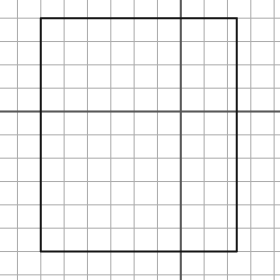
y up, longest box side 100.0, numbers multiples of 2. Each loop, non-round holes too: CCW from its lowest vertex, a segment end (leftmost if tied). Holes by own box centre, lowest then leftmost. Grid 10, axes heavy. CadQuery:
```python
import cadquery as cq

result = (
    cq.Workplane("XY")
    .moveTo(-60.0, -60.0)
    .lineTo(24.0, -60.0)
    .lineTo(24.0, 40.0)
    .lineTo(-60.0, 40.0)
    .close()
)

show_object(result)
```